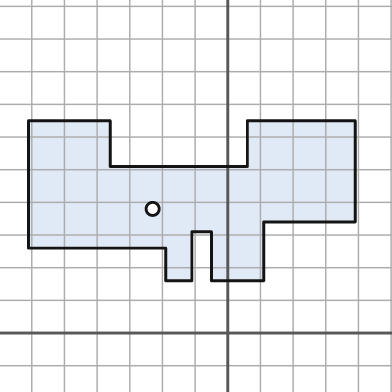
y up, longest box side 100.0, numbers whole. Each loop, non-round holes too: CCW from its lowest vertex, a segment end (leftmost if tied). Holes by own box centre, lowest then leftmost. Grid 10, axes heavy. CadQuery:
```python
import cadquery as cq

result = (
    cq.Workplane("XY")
    .moveTo(-19.0, 16.0)
    .lineTo(-11.0, 16.0)
    .lineTo(-11.0, 31.0)
    .lineTo(-5.0, 31.0)
    .lineTo(-5.0, 16.0)
    .lineTo(11.0, 16.0)
    .lineTo(11.0, 34.0)
    .lineTo(39.0, 34.0)
    .lineTo(39.0, 65.0)
    .lineTo(6.0, 65.0)
    .lineTo(6.0, 51.0)
    .lineTo(-36.0, 51.0)
    .lineTo(-36.0, 65.0)
    .lineTo(-61.0, 65.0)
    .lineTo(-61.0, 26.0)
    .lineTo(-19.0, 26.0)
    .close()
    .moveTo(-23.0, 38.0)
    .circle(2.0)
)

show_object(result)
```